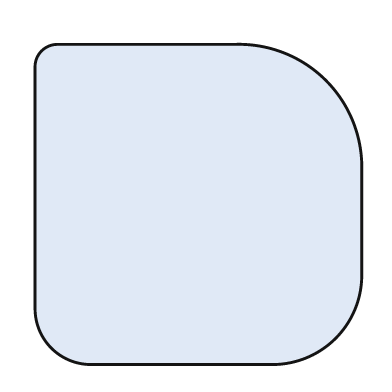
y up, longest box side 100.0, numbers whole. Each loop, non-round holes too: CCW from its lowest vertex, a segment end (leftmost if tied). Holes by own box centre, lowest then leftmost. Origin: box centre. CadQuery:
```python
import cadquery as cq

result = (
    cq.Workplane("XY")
    .moveTo(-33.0, -49.0)
    .lineTo(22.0, -49.0)
    .threePointArc((42.0, -41.0), (50.0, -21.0))
    .lineTo(50.0, 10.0)
    .threePointArc((39.0, 38.0), (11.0, 49.0))
    .lineTo(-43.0, 49.0)
    .threePointArc((-48.0, 47.0), (-50.0, 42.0))
    .lineTo(-50.0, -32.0)
    .threePointArc((-45.0, -44.0), (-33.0, -49.0))
    .close()
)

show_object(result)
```